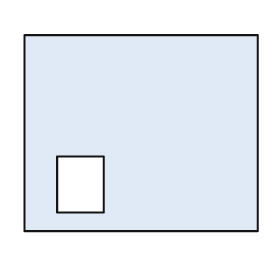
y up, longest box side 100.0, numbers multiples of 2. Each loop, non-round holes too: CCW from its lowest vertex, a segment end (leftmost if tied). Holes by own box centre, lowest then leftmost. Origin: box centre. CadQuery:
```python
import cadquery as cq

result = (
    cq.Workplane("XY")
    .moveTo(-50.0, -42.0)
    .lineTo(50.0, -42.0)
    .lineTo(50.0, 42.0)
    .lineTo(-50.0, 42.0)
    .close()
    .moveTo(-36.0, -34.0)
    .lineTo(-16.0, -34.0)
    .lineTo(-16.0, -10.0)
    .lineTo(-36.0, -10.0)
    .close()
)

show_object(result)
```